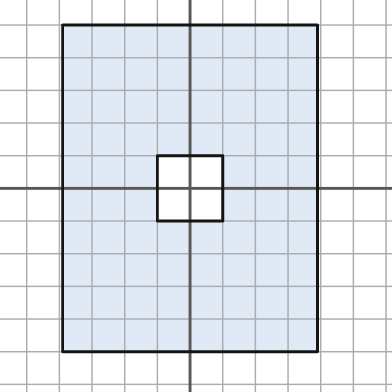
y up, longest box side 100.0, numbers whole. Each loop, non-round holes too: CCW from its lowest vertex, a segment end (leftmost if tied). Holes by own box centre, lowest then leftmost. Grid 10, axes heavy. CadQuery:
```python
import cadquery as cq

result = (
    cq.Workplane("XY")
    .moveTo(-39.0, -50.0)
    .lineTo(39.0, -50.0)
    .lineTo(39.0, 50.0)
    .lineTo(-39.0, 50.0)
    .close()
    .moveTo(-10.0, -10.0)
    .lineTo(10.0, -10.0)
    .lineTo(10.0, 10.0)
    .lineTo(-10.0, 10.0)
    .close()
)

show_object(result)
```